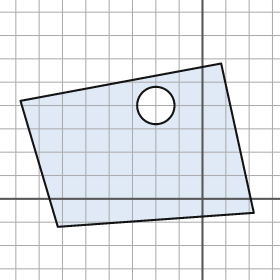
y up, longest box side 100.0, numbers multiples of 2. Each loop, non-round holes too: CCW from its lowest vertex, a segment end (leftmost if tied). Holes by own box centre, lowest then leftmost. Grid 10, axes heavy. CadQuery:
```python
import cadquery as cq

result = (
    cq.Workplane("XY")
    .moveTo(-62.0, -12.0)
    .lineTo(22.0, -6.0)
    .lineTo(8.0, 58.0)
    .lineTo(-78.0, 42.0)
    .close()
    .moveTo(-20.0, 40.0)
    .circle(8.0)
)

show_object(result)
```